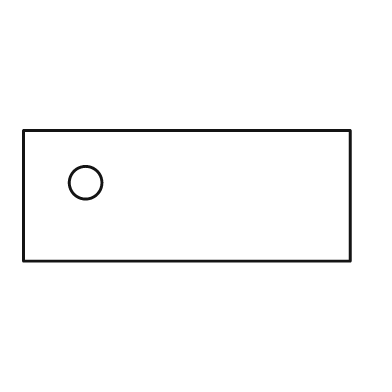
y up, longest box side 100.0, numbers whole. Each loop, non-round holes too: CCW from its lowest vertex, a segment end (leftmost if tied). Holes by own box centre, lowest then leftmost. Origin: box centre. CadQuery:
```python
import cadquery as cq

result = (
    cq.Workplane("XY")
    .moveTo(-50.0, -20.0)
    .lineTo(50.0, -20.0)
    .lineTo(50.0, 20.0)
    .lineTo(-50.0, 20.0)
    .close()
    .moveTo(-31.0, 4.0)
    .circle(5.0)
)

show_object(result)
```